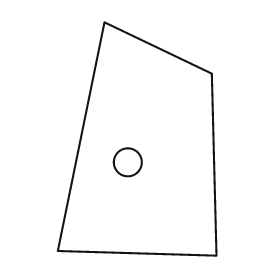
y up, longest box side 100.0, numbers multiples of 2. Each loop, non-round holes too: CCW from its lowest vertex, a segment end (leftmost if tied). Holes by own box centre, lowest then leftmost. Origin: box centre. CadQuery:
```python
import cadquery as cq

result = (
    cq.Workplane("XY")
    .moveTo(34.0, -50.0)
    .lineTo(32.0, 28.0)
    .lineTo(-14.0, 50.0)
    .lineTo(-34.0, -48.0)
    .close()
    .moveTo(-4.0, -10.0)
    .circle(6.0)
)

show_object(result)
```